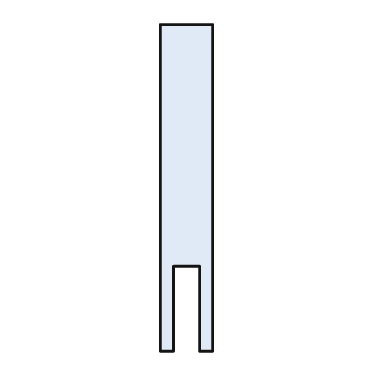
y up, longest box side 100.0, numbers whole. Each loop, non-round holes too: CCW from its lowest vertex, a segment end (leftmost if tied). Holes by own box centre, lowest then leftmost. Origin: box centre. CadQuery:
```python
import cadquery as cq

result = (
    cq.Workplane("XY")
    .moveTo(-8.0, -50.0)
    .lineTo(-4.0, -50.0)
    .lineTo(-4.0, -24.0)
    .lineTo(4.0, -24.0)
    .lineTo(4.0, -50.0)
    .lineTo(8.0, -50.0)
    .lineTo(8.0, 50.0)
    .lineTo(-8.0, 50.0)
    .close()
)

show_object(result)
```